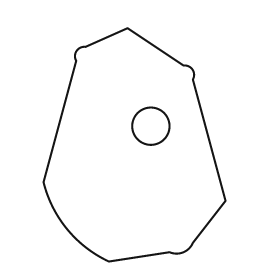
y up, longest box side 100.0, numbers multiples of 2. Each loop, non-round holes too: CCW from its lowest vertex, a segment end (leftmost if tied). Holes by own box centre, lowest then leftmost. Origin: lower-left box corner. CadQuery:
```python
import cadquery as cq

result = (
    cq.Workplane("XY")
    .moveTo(28.0, 0.0)
    .lineTo(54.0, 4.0)
    .threePointArc((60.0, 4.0), (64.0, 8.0))
    .lineTo(78.0, 26.0)
    .lineTo(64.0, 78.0)
    .threePointArc((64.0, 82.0), (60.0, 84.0))
    .lineTo(36.0, 100.0)
    .lineTo(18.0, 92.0)
    .threePointArc((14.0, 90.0), (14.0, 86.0))
    .lineTo(0.0, 34.0)
    .threePointArc((10.0, 14.0), (28.0, 0.0))
    .close()
    .moveTo(46.0, 58.0)
    .circle(8.0)
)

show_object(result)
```